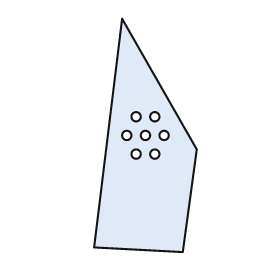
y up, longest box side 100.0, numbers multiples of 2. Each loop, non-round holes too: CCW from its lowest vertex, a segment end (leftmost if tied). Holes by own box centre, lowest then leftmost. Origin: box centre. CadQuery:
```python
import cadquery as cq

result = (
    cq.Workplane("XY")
    .moveTo(16.0, -50.0)
    .lineTo(22.0, -6.0)
    .lineTo(-10.0, 50.0)
    .lineTo(-22.0, -48.0)
    .close()
    .moveTo(-4.0, -8.0)
    .circle(2.0)
    .moveTo(4.0, -8.0)
    .circle(2.0)
    .moveTo(-8.0, 0.0)
    .circle(2.0)
    .moveTo(0.0, 0.0)
    .circle(2.0)
    .moveTo(8.0, 0.0)
    .circle(2.0)
    .moveTo(-4.0, 8.0)
    .circle(2.0)
    .moveTo(4.0, 8.0)
    .circle(2.0)
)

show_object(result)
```